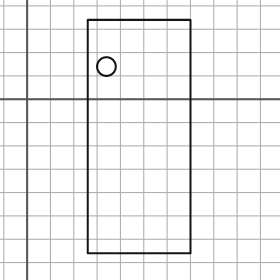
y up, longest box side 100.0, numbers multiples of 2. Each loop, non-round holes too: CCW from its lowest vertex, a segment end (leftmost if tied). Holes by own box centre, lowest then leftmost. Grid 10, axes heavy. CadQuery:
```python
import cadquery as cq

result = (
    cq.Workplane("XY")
    .moveTo(26.0, -66.0)
    .lineTo(70.0, -66.0)
    .lineTo(70.0, 34.0)
    .lineTo(26.0, 34.0)
    .close()
    .moveTo(34.0, 14.0)
    .circle(4.0)
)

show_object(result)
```